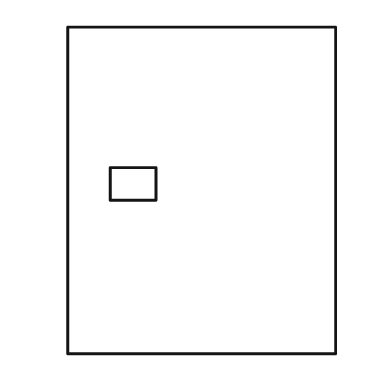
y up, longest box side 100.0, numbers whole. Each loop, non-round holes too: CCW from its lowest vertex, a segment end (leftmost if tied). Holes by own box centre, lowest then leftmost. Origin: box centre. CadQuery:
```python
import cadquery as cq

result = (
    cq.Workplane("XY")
    .moveTo(-41.0, -50.0)
    .lineTo(41.0, -50.0)
    .lineTo(41.0, 50.0)
    .lineTo(-41.0, 50.0)
    .close()
    .moveTo(-28.0, -3.0)
    .lineTo(-14.0, -3.0)
    .lineTo(-14.0, 7.0)
    .lineTo(-28.0, 7.0)
    .close()
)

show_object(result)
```